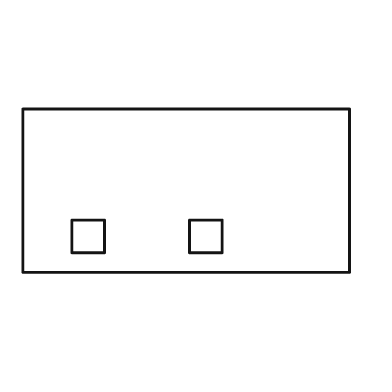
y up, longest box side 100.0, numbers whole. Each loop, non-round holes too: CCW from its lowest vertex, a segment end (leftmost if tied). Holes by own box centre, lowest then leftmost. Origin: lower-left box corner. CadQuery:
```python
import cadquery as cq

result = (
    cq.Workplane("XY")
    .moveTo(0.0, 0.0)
    .lineTo(100.0, 0.0)
    .lineTo(100.0, 50.0)
    .lineTo(0.0, 50.0)
    .close()
    .moveTo(15.0, 6.0)
    .lineTo(25.0, 6.0)
    .lineTo(25.0, 16.0)
    .lineTo(15.0, 16.0)
    .close()
    .moveTo(51.0, 6.0)
    .lineTo(61.0, 6.0)
    .lineTo(61.0, 16.0)
    .lineTo(51.0, 16.0)
    .close()
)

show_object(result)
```